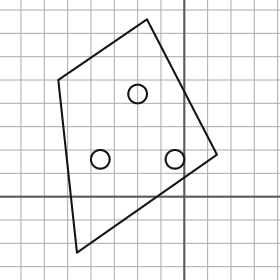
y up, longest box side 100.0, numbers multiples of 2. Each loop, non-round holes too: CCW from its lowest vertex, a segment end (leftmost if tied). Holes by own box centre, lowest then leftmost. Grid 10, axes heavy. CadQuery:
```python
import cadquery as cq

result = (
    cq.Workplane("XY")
    .moveTo(-46.0, -24.0)
    .lineTo(14.0, 18.0)
    .lineTo(-16.0, 76.0)
    .lineTo(-54.0, 50.0)
    .close()
    .moveTo(-36.0, 16.0)
    .circle(4.0)
    .moveTo(-4.0, 16.0)
    .circle(4.0)
    .moveTo(-20.0, 44.0)
    .circle(4.0)
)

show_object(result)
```